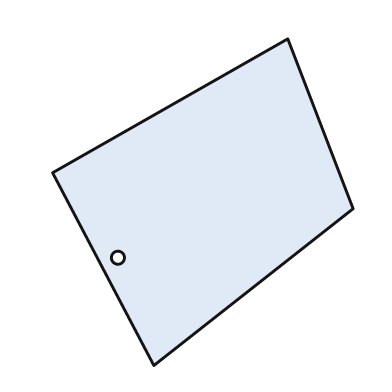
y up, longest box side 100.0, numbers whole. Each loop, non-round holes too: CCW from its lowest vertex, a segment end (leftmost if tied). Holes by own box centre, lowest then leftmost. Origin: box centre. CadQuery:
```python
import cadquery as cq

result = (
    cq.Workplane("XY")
    .moveTo(-15.0, -50.0)
    .lineTo(46.0, -2.0)
    .lineTo(26.0, 50.0)
    .lineTo(-46.0, 9.0)
    .close()
    .moveTo(-26.0, -17.0)
    .circle(2.0)
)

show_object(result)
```